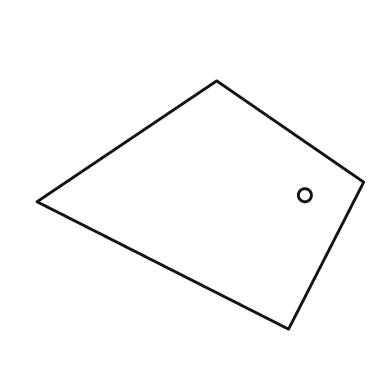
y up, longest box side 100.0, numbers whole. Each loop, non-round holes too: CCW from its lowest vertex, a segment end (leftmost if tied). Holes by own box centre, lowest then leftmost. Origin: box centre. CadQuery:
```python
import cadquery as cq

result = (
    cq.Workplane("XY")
    .moveTo(27.0, -38.0)
    .lineTo(50.0, 7.0)
    .lineTo(5.0, 38.0)
    .lineTo(-50.0, 1.0)
    .close()
    .moveTo(32.0, 3.0)
    .circle(2.0)
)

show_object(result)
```